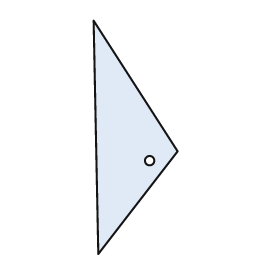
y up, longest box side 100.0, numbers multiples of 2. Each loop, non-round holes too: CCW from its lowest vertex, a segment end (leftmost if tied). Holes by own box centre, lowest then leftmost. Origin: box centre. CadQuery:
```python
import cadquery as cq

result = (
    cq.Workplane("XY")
    .moveTo(-16.0, -50.0)
    .lineTo(18.0, -6.0)
    .lineTo(-18.0, 50.0)
    .close()
    .moveTo(6.0, -10.0)
    .circle(2.0)
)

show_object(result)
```